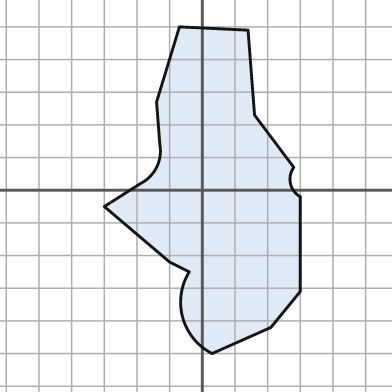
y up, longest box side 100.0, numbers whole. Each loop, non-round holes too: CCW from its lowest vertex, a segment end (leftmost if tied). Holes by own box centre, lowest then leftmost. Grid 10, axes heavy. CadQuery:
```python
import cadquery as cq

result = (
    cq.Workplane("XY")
    .moveTo(3.0, -50.0)
    .lineTo(21.0, -42.0)
    .lineTo(30.0, -31.0)
    .lineTo(30.0, -2.0)
    .threePointArc((27.0, 2.0), (28.0, 7.0))
    .lineTo(16.0, 23.0)
    .lineTo(14.0, 49.0)
    .lineTo(-7.0, 50.0)
    .lineTo(-14.0, 27.0)
    .lineTo(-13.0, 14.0)
    .threePointArc((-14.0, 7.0), (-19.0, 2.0))
    .lineTo(-30.0, -5.0)
    .lineTo(-10.0, -22.0)
    .lineTo(-4.0, -25.0)
    .threePointArc((-6.0, -39.0), (3.0, -50.0))
    .close()
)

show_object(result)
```